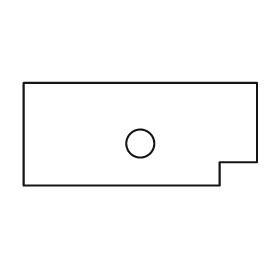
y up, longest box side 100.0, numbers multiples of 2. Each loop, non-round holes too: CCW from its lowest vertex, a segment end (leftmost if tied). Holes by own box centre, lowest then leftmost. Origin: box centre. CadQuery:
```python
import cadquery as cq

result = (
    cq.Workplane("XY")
    .moveTo(-50.0, -22.0)
    .lineTo(34.0, -22.0)
    .lineTo(34.0, -12.0)
    .lineTo(50.0, -12.0)
    .lineTo(50.0, 22.0)
    .lineTo(-50.0, 22.0)
    .close()
    .moveTo(0.0, -4.0)
    .circle(6.0)
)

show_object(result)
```